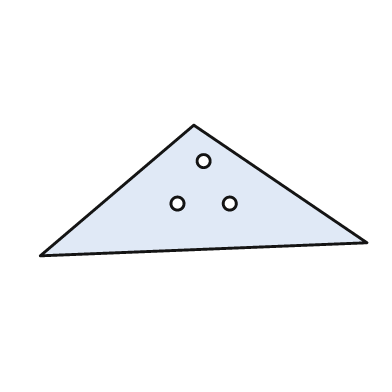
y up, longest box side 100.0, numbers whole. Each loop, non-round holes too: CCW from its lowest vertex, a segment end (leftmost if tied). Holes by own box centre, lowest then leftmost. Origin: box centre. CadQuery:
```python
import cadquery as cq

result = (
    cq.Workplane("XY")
    .moveTo(-50.0, -20.0)
    .lineTo(50.0, -16.0)
    .lineTo(-3.0, 20.0)
    .close()
    .moveTo(-8.0, -4.0)
    .circle(2.0)
    .moveTo(8.0, -4.0)
    .circle(2.0)
    .moveTo(0.0, 9.0)
    .circle(2.0)
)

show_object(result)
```